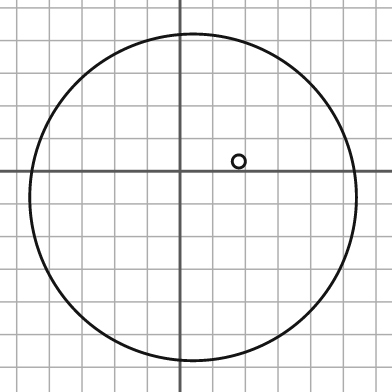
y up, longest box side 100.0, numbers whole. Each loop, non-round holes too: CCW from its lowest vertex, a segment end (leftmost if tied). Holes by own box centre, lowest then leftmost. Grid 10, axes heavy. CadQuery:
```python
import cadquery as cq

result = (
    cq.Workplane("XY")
    .moveTo(4.0, -8.0)
    .circle(50.0)
    .moveTo(18.0, 3.0)
    .circle(2.0)
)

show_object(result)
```